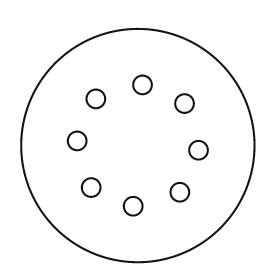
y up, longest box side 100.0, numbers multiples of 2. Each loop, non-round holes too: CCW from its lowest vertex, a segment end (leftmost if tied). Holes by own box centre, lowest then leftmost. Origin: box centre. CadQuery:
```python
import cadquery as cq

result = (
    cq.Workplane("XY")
    .moveTo(0.0, 0.0)
    .circle(50.0)
    .moveTo(-2.0, -26.0)
    .circle(4.0)
    .moveTo(18.0, -20.0)
    .circle(4.0)
    .moveTo(-20.0, -18.0)
    .circle(4.0)
    .moveTo(26.0, -2.0)
    .circle(4.0)
    .moveTo(-26.0, 2.0)
    .circle(4.0)
    .moveTo(20.0, 18.0)
    .circle(4.0)
    .moveTo(-18.0, 20.0)
    .circle(4.0)
    .moveTo(2.0, 26.0)
    .circle(4.0)
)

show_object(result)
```